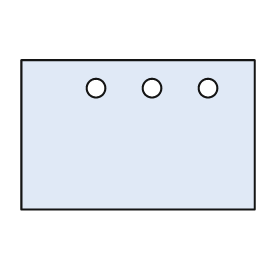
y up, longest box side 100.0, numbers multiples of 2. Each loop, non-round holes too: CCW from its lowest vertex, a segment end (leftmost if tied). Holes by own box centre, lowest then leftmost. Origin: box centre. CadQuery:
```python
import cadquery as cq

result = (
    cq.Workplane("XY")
    .moveTo(-50.0, -32.0)
    .lineTo(50.0, -32.0)
    .lineTo(50.0, 32.0)
    .lineTo(-50.0, 32.0)
    .close()
    .moveTo(-18.0, 20.0)
    .circle(4.0)
    .moveTo(6.0, 20.0)
    .circle(4.0)
    .moveTo(30.0, 20.0)
    .circle(4.0)
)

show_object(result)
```